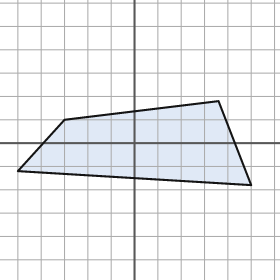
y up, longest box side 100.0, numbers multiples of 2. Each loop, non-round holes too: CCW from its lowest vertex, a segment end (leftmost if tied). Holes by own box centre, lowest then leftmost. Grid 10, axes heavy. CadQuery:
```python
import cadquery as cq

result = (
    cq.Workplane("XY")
    .moveTo(50.0, -18.0)
    .lineTo(36.0, 18.0)
    .lineTo(-30.0, 10.0)
    .lineTo(-50.0, -12.0)
    .close()
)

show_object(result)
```